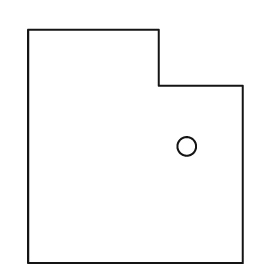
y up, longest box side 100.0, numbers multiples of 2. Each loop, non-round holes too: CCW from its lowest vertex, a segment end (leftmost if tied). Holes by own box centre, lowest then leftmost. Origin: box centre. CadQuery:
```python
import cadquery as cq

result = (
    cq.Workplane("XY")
    .moveTo(-46.0, -50.0)
    .lineTo(46.0, -50.0)
    .lineTo(46.0, 26.0)
    .lineTo(10.0, 26.0)
    .lineTo(10.0, 50.0)
    .lineTo(-46.0, 50.0)
    .close()
    .moveTo(22.0, 0.0)
    .circle(4.0)
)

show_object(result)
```